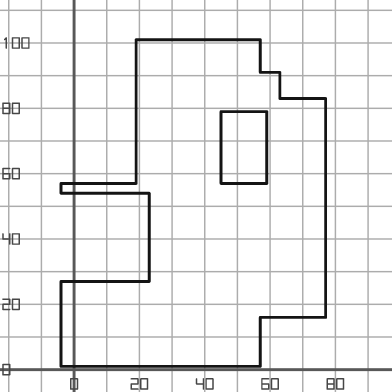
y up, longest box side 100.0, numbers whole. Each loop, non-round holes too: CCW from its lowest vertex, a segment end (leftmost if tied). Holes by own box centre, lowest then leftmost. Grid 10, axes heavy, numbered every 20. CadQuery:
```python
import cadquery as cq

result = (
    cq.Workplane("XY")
    .moveTo(-4.0, 1.0)
    .lineTo(57.0, 1.0)
    .lineTo(57.0, 16.0)
    .lineTo(77.0, 16.0)
    .lineTo(77.0, 83.0)
    .lineTo(63.0, 83.0)
    .lineTo(63.0, 91.0)
    .lineTo(57.0, 91.0)
    .lineTo(57.0, 101.0)
    .lineTo(19.0, 101.0)
    .lineTo(19.0, 57.0)
    .lineTo(-4.0, 57.0)
    .lineTo(-4.0, 54.0)
    .lineTo(23.0, 54.0)
    .lineTo(23.0, 27.0)
    .lineTo(-4.0, 27.0)
    .close()
    .moveTo(45.0, 57.0)
    .lineTo(59.0, 57.0)
    .lineTo(59.0, 79.0)
    .lineTo(45.0, 79.0)
    .close()
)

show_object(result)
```